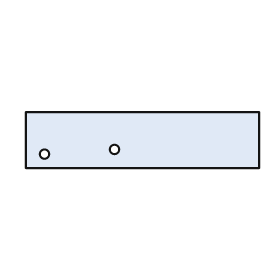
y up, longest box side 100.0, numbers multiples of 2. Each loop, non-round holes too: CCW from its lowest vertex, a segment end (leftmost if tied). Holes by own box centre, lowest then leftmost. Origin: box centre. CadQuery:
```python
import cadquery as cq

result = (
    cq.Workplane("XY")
    .moveTo(-50.0, -12.0)
    .lineTo(50.0, -12.0)
    .lineTo(50.0, 12.0)
    .lineTo(-50.0, 12.0)
    .close()
    .moveTo(-42.0, -6.0)
    .circle(2.0)
    .moveTo(-12.0, -4.0)
    .circle(2.0)
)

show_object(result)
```